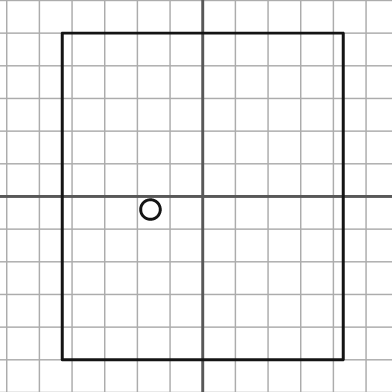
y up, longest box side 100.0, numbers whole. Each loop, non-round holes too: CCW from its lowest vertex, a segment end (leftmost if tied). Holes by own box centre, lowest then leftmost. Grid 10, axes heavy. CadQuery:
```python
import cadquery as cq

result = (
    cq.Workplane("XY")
    .moveTo(-43.0, -50.0)
    .lineTo(43.0, -50.0)
    .lineTo(43.0, 50.0)
    .lineTo(-43.0, 50.0)
    .close()
    .moveTo(-16.0, -4.0)
    .circle(3.0)
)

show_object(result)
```